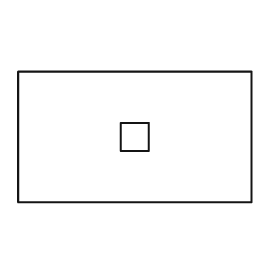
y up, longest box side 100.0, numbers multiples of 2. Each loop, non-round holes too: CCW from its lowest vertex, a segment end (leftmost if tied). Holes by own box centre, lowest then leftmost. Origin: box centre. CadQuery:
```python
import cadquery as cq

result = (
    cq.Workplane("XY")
    .moveTo(-50.0, -28.0)
    .lineTo(50.0, -28.0)
    .lineTo(50.0, 28.0)
    .lineTo(-50.0, 28.0)
    .close()
    .moveTo(-6.0, -6.0)
    .lineTo(6.0, -6.0)
    .lineTo(6.0, 6.0)
    .lineTo(-6.0, 6.0)
    .close()
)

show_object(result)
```